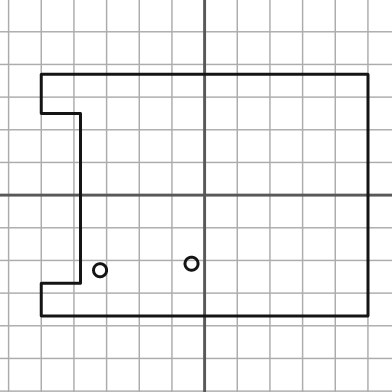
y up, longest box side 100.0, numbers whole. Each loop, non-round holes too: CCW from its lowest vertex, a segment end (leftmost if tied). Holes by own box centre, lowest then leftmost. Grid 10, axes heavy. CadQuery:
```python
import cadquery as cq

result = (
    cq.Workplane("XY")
    .moveTo(-50.0, -37.0)
    .lineTo(50.0, -37.0)
    .lineTo(50.0, 37.0)
    .lineTo(-50.0, 37.0)
    .lineTo(-50.0, 25.0)
    .lineTo(-38.0, 25.0)
    .lineTo(-38.0, -27.0)
    .lineTo(-50.0, -27.0)
    .close()
    .moveTo(-32.0, -23.0)
    .circle(2.0)
    .moveTo(-4.0, -21.0)
    .circle(2.0)
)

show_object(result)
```